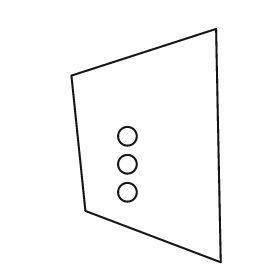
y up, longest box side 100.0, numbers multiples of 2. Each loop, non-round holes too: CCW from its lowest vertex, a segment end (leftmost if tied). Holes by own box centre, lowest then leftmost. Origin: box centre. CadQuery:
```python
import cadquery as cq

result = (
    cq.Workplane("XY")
    .moveTo(32.0, -50.0)
    .lineTo(30.0, 50.0)
    .lineTo(-32.0, 30.0)
    .lineTo(-26.0, -28.0)
    .close()
    .moveTo(-8.0, -20.0)
    .circle(4.0)
    .moveTo(-8.0, -8.0)
    .circle(4.0)
    .moveTo(-8.0, 4.0)
    .circle(4.0)
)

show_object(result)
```